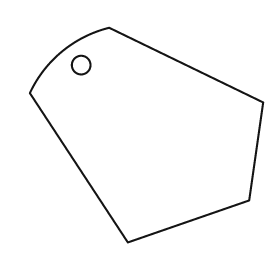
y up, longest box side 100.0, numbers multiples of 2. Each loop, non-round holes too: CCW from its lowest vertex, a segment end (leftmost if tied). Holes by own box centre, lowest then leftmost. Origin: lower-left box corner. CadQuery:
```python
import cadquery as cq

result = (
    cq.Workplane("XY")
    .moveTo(42.0, 0.0)
    .lineTo(94.0, 18.0)
    .lineTo(100.0, 60.0)
    .lineTo(34.0, 92.0)
    .threePointArc((14.0, 82.0), (0.0, 64.0))
    .close()
    .moveTo(22.0, 76.0)
    .circle(4.0)
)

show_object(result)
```